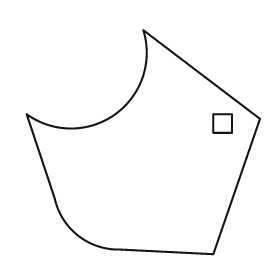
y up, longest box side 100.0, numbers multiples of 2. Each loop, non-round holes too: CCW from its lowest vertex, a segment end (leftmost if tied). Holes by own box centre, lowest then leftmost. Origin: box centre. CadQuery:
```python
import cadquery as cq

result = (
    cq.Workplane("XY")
    .moveTo(30.0, -48.0)
    .lineTo(50.0, 10.0)
    .lineTo(0.0, 48.0)
    .threePointArc((-12.0, 12.0), (-50.0, 12.0))
    .lineTo(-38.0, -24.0)
    .threePointArc((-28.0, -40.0), (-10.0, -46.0))
    .close()
    .moveTo(30.0, 4.0)
    .lineTo(38.0, 4.0)
    .lineTo(38.0, 12.0)
    .lineTo(30.0, 12.0)
    .close()
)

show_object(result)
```